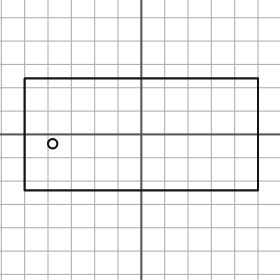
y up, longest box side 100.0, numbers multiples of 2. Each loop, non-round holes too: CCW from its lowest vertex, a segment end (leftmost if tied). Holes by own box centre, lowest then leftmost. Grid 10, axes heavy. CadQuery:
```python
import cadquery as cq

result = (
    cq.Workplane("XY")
    .moveTo(-50.0, -24.0)
    .lineTo(50.0, -24.0)
    .lineTo(50.0, 24.0)
    .lineTo(-50.0, 24.0)
    .close()
    .moveTo(-38.0, -4.0)
    .circle(2.0)
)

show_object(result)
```